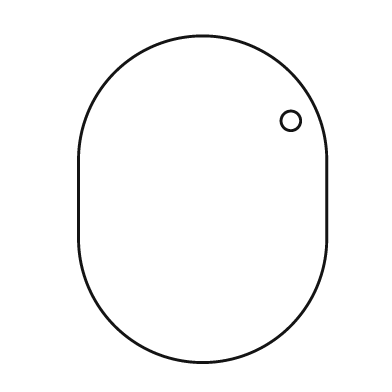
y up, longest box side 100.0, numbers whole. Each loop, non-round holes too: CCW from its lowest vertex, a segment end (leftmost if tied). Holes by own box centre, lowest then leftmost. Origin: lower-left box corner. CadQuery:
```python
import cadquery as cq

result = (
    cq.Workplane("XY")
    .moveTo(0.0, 38.0)
    .threePointArc((38.0, 0.0), (76.0, 38.0))
    .lineTo(76.0, 62.0)
    .threePointArc((38.0, 100.0), (0.0, 62.0))
    .close()
    .moveTo(65.0, 74.0)
    .circle(3.0)
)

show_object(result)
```